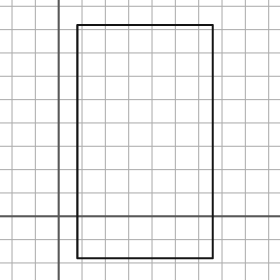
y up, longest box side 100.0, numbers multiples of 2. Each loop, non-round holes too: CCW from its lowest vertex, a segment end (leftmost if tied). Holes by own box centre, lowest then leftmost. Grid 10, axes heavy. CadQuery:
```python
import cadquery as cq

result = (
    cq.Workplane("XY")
    .moveTo(8.0, -18.0)
    .lineTo(66.0, -18.0)
    .lineTo(66.0, 82.0)
    .lineTo(8.0, 82.0)
    .close()
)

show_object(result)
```